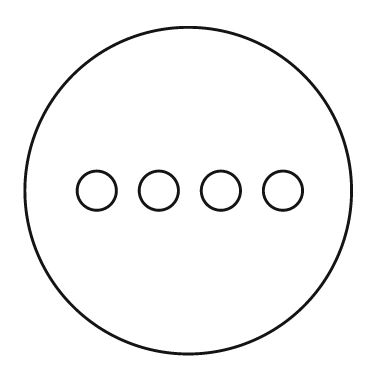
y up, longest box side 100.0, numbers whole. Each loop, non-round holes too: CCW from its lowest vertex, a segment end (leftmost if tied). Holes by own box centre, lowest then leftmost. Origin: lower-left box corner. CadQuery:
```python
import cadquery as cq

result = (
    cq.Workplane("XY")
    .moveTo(50.0, 50.0)
    .circle(50.0)
    .moveTo(22.0, 50.0)
    .circle(6.0)
    .moveTo(41.0, 50.0)
    .circle(6.0)
    .moveTo(60.0, 50.0)
    .circle(6.0)
    .moveTo(79.0, 50.0)
    .circle(6.0)
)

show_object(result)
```